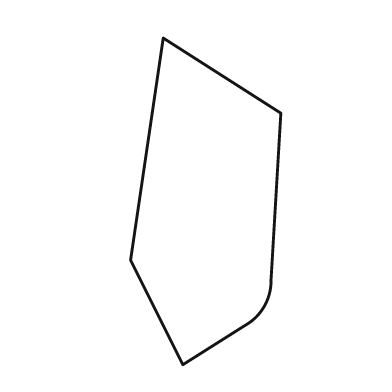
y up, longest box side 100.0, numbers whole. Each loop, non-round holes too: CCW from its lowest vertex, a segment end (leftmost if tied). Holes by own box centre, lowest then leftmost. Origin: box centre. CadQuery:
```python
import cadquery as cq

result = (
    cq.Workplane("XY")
    .moveTo(-7.0, -50.0)
    .lineTo(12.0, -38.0)
    .threePointArc((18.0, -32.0), (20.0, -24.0))
    .lineTo(23.0, 27.0)
    .lineTo(-13.0, 50.0)
    .lineTo(-23.0, -18.0)
    .close()
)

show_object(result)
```